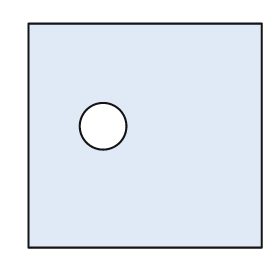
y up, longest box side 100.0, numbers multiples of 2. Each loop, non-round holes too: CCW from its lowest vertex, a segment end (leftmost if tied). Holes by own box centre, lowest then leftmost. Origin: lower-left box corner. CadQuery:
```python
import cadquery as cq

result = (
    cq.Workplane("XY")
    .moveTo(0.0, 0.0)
    .lineTo(100.0, 0.0)
    .lineTo(100.0, 96.0)
    .lineTo(0.0, 96.0)
    .close()
    .moveTo(32.0, 52.0)
    .circle(10.0)
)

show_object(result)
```